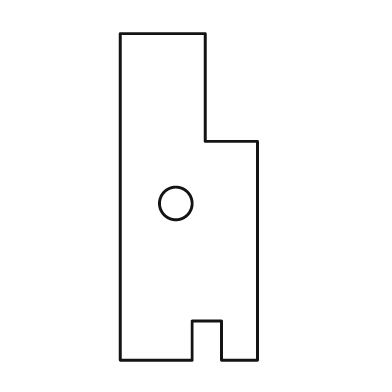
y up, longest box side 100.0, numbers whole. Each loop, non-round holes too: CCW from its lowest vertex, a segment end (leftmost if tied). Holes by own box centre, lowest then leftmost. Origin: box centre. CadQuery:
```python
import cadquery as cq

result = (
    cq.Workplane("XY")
    .moveTo(-21.0, -50.0)
    .lineTo(1.0, -50.0)
    .lineTo(1.0, -38.0)
    .lineTo(10.0, -38.0)
    .lineTo(10.0, -50.0)
    .lineTo(21.0, -50.0)
    .lineTo(21.0, 17.0)
    .lineTo(5.0, 17.0)
    .lineTo(5.0, 50.0)
    .lineTo(-21.0, 50.0)
    .close()
    .moveTo(-4.0, -2.0)
    .circle(5.0)
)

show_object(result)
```